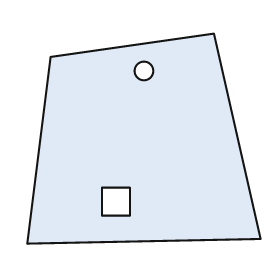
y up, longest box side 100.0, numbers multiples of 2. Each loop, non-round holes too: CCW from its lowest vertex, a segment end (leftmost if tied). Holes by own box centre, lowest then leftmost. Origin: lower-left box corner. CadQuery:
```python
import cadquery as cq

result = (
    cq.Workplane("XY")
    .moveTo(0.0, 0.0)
    .lineTo(100.0, 2.0)
    .lineTo(80.0, 90.0)
    .lineTo(10.0, 80.0)
    .close()
    .moveTo(32.0, 12.0)
    .lineTo(44.0, 12.0)
    .lineTo(44.0, 24.0)
    .lineTo(32.0, 24.0)
    .close()
    .moveTo(50.0, 74.0)
    .circle(4.0)
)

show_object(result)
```